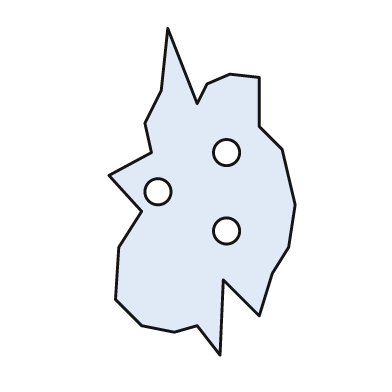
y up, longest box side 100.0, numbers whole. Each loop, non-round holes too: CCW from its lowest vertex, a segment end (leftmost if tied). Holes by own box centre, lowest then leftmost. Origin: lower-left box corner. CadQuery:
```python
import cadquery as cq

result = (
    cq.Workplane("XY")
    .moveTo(34.0, 0.0)
    .lineTo(35.0, 23.0)
    .lineTo(46.0, 12.0)
    .lineTo(50.0, 25.0)
    .lineTo(55.0, 33.0)
    .lineTo(57.0, 46.0)
    .lineTo(53.0, 63.0)
    .lineTo(46.0, 70.0)
    .lineTo(46.0, 85.0)
    .lineTo(37.0, 86.0)
    .lineTo(30.0, 83.0)
    .lineTo(27.0, 77.0)
    .lineTo(18.0, 100.0)
    .lineTo(16.0, 81.0)
    .lineTo(11.0, 71.0)
    .lineTo(13.0, 62.0)
    .lineTo(0.0, 55.0)
    .lineTo(10.0, 44.0)
    .lineTo(3.0, 33.0)
    .lineTo(2.0, 17.0)
    .lineTo(10.0, 9.0)
    .lineTo(20.0, 7.0)
    .lineTo(27.0, 9.0)
    .close()
    .moveTo(36.0, 38.0)
    .circle(4.0)
    .moveTo(15.0, 50.0)
    .circle(4.0)
    .moveTo(36.0, 62.0)
    .circle(4.0)
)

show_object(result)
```